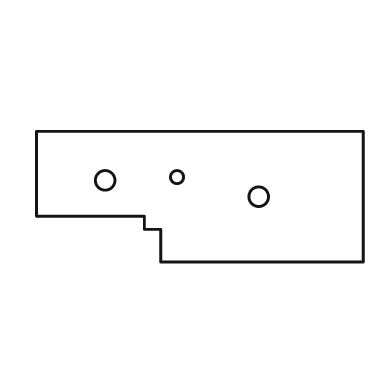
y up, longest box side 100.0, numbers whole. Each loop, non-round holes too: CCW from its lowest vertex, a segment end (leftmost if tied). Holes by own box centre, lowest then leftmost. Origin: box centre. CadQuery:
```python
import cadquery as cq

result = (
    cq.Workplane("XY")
    .moveTo(-12.0, -20.0)
    .lineTo(50.0, -20.0)
    .lineTo(50.0, 20.0)
    .lineTo(-50.0, 20.0)
    .lineTo(-50.0, -6.0)
    .lineTo(-17.0, -6.0)
    .lineTo(-17.0, -10.0)
    .lineTo(-12.0, -10.0)
    .close()
    .moveTo(18.0, 0.0)
    .circle(3.0)
    .moveTo(-29.0, 5.0)
    .circle(3.0)
    .moveTo(-7.0, 6.0)
    .circle(2.0)
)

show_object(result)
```